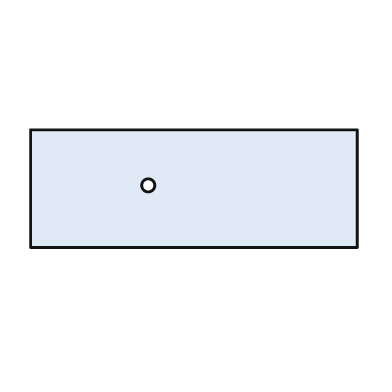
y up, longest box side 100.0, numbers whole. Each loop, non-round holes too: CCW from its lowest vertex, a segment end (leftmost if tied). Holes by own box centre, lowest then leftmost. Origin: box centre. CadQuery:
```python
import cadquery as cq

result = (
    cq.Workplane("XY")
    .moveTo(-50.0, -18.0)
    .lineTo(50.0, -18.0)
    .lineTo(50.0, 18.0)
    .lineTo(-50.0, 18.0)
    .close()
    .moveTo(-14.0, 1.0)
    .circle(2.0)
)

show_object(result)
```